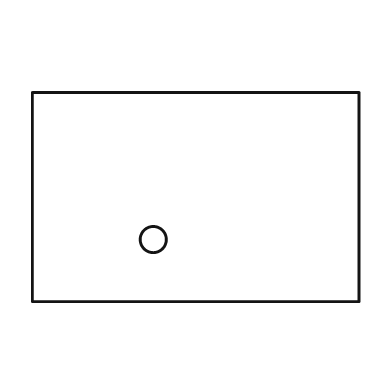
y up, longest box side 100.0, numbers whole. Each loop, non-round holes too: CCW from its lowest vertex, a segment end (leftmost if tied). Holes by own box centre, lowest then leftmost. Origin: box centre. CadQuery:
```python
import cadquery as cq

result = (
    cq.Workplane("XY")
    .moveTo(-50.0, -32.0)
    .lineTo(50.0, -32.0)
    .lineTo(50.0, 32.0)
    .lineTo(-50.0, 32.0)
    .close()
    .moveTo(-13.0, -13.0)
    .circle(4.0)
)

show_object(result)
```